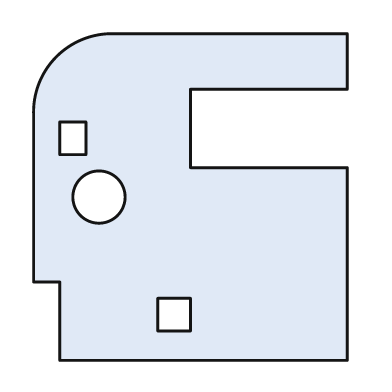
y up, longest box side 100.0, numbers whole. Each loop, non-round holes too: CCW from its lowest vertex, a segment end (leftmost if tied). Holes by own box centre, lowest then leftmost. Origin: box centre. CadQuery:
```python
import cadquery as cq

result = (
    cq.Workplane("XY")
    .moveTo(-40.0, -50.0)
    .lineTo(48.0, -50.0)
    .lineTo(48.0, 9.0)
    .lineTo(0.0, 9.0)
    .lineTo(0.0, 33.0)
    .lineTo(48.0, 33.0)
    .lineTo(48.0, 50.0)
    .lineTo(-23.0, 50.0)
    .threePointArc((-41.0, 43.0), (-48.0, 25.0))
    .lineTo(-48.0, -26.0)
    .lineTo(-40.0, -26.0)
    .close()
    .moveTo(-10.0, -41.0)
    .lineTo(0.0, -41.0)
    .lineTo(0.0, -31.0)
    .lineTo(-10.0, -31.0)
    .close()
    .moveTo(-28.0, 0.0)
    .circle(8.0)
    .moveTo(-40.0, 13.0)
    .lineTo(-32.0, 13.0)
    .lineTo(-32.0, 23.0)
    .lineTo(-40.0, 23.0)
    .close()
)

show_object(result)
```